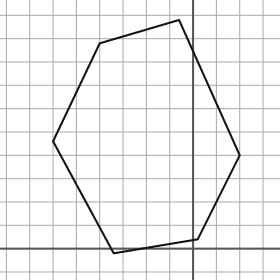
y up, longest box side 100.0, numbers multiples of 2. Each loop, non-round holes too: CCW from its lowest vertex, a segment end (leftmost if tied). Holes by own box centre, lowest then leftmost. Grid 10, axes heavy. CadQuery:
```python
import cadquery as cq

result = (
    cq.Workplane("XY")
    .moveTo(-34.0, -2.0)
    .lineTo(2.0, 4.0)
    .lineTo(20.0, 40.0)
    .lineTo(-6.0, 98.0)
    .lineTo(-40.0, 88.0)
    .lineTo(-60.0, 46.0)
    .close()
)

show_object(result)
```